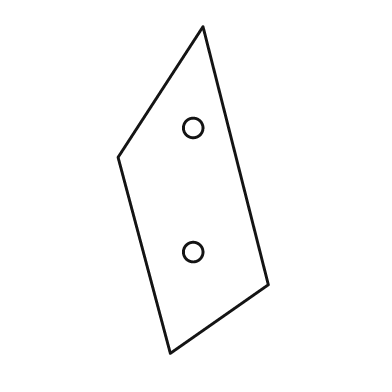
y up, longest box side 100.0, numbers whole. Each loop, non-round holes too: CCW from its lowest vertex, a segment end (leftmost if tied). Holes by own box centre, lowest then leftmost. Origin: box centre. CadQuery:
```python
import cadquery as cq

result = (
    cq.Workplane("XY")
    .moveTo(-7.0, -50.0)
    .lineTo(23.0, -29.0)
    .lineTo(3.0, 50.0)
    .lineTo(-23.0, 10.0)
    .close()
    .moveTo(0.0, -19.0)
    .circle(3.0)
    .moveTo(0.0, 19.0)
    .circle(3.0)
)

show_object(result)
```